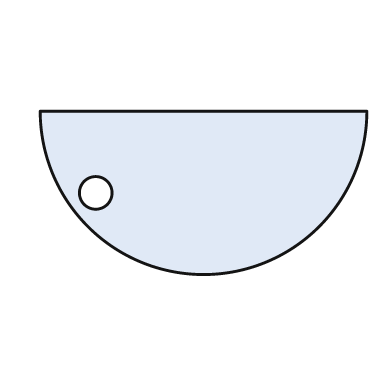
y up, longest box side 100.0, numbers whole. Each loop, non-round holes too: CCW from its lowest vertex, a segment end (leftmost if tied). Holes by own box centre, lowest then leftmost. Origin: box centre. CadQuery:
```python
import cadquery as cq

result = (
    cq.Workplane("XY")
    .moveTo(-50.0, 25.0)
    .threePointArc((0.0, -25.0), (50.0, 25.0))
    .close()
    .moveTo(-33.0, 0.0)
    .circle(5.0)
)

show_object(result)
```